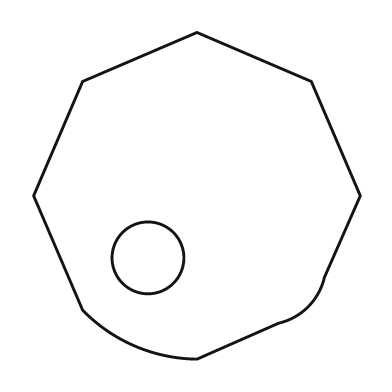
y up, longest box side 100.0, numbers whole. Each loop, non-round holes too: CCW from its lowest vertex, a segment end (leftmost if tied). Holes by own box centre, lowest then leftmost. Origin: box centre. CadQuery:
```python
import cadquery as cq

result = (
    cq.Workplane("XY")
    .moveTo(0.0, -50.0)
    .lineTo(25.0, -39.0)
    .threePointArc((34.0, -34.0), (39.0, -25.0))
    .lineTo(50.0, 0.0)
    .lineTo(35.0, 35.0)
    .lineTo(0.0, 50.0)
    .lineTo(-35.0, 35.0)
    .lineTo(-50.0, 0.0)
    .lineTo(-35.0, -35.0)
    .threePointArc((-19.0, -46.0), (0.0, -50.0))
    .close()
    .moveTo(-15.0, -19.0)
    .circle(11.0)
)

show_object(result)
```